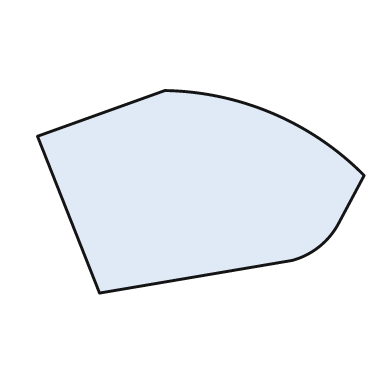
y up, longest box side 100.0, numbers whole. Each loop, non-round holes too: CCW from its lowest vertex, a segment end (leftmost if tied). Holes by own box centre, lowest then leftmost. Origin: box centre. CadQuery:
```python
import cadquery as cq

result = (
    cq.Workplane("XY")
    .moveTo(-31.0, -31.0)
    .lineTo(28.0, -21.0)
    .threePointArc((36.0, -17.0), (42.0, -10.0))
    .lineTo(50.0, 5.0)
    .threePointArc((22.0, 24.0), (-11.0, 31.0))
    .lineTo(-50.0, 17.0)
    .close()
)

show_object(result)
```